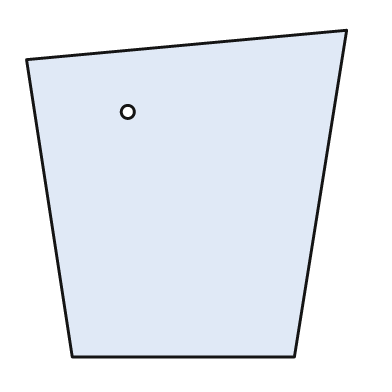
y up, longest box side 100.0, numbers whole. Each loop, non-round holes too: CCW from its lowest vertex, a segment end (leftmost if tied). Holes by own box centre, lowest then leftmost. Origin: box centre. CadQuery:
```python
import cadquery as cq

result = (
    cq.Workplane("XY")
    .moveTo(-35.0, -50.0)
    .lineTo(33.0, -50.0)
    .lineTo(49.0, 50.0)
    .lineTo(-49.0, 41.0)
    .close()
    .moveTo(-18.0, 25.0)
    .circle(2.0)
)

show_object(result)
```